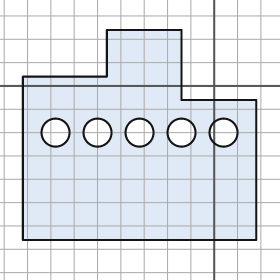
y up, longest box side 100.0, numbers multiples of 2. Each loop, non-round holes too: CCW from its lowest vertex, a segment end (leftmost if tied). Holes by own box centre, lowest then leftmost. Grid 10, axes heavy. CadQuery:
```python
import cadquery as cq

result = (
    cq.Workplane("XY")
    .moveTo(-82.0, -66.0)
    .lineTo(18.0, -66.0)
    .lineTo(18.0, -6.0)
    .lineTo(-14.0, -6.0)
    .lineTo(-14.0, 24.0)
    .lineTo(-46.0, 24.0)
    .lineTo(-46.0, 4.0)
    .lineTo(-82.0, 4.0)
    .close()
    .moveTo(-68.0, -20.0)
    .circle(6.0)
    .moveTo(-50.0, -20.0)
    .circle(6.0)
    .moveTo(-32.0, -20.0)
    .circle(6.0)
    .moveTo(-14.0, -20.0)
    .circle(6.0)
    .moveTo(4.0, -20.0)
    .circle(6.0)
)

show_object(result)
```